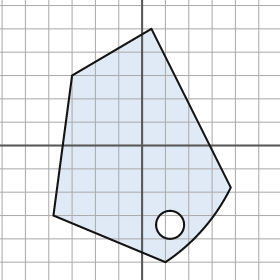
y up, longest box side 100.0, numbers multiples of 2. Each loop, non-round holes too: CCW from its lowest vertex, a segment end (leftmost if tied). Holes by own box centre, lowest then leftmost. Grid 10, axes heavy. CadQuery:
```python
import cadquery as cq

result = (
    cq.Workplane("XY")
    .moveTo(10.0, -50.0)
    .threePointArc((26.0, -36.0), (38.0, -18.0))
    .lineTo(4.0, 50.0)
    .lineTo(-30.0, 30.0)
    .lineTo(-38.0, -30.0)
    .close()
    .moveTo(12.0, -34.0)
    .circle(6.0)
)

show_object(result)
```